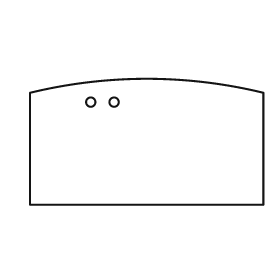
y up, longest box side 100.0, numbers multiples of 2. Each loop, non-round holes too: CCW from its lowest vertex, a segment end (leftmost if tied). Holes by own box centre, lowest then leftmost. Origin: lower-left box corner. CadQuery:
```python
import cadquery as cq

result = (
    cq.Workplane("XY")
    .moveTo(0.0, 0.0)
    .lineTo(100.0, 0.0)
    .lineTo(100.0, 48.0)
    .threePointArc((50.0, 54.0), (0.0, 48.0))
    .close()
    .moveTo(26.0, 44.0)
    .circle(2.0)
    .moveTo(36.0, 44.0)
    .circle(2.0)
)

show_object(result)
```